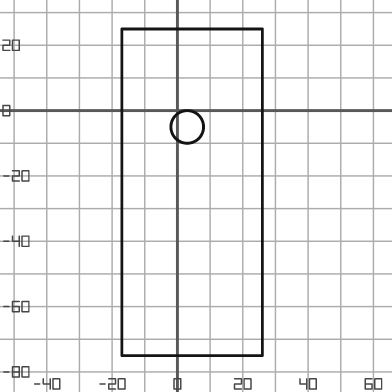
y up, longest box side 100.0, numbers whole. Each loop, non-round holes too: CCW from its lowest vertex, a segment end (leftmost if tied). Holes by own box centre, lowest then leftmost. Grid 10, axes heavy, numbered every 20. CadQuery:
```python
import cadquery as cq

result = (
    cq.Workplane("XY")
    .moveTo(-17.0, -75.0)
    .lineTo(26.0, -75.0)
    .lineTo(26.0, 25.0)
    .lineTo(-17.0, 25.0)
    .close()
    .moveTo(3.0, -5.0)
    .circle(5.0)
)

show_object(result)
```